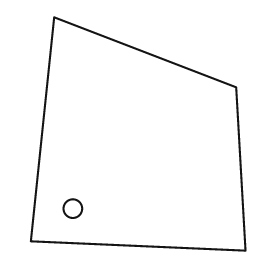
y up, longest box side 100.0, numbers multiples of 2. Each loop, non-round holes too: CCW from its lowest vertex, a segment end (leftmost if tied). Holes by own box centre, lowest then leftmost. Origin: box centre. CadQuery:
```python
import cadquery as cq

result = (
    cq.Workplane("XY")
    .moveTo(46.0, -50.0)
    .lineTo(42.0, 20.0)
    .lineTo(-36.0, 50.0)
    .lineTo(-46.0, -46.0)
    .close()
    .moveTo(-28.0, -32.0)
    .circle(4.0)
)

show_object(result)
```